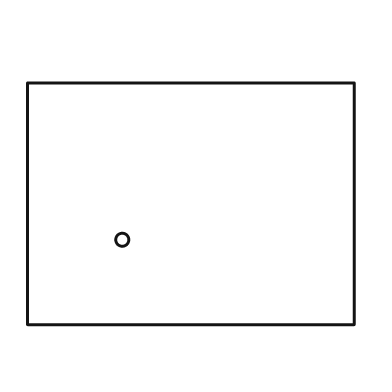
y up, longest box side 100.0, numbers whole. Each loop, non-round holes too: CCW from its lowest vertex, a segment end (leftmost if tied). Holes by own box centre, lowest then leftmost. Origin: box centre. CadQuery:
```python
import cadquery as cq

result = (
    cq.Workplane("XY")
    .moveTo(-50.0, -37.0)
    .lineTo(50.0, -37.0)
    .lineTo(50.0, 37.0)
    .lineTo(-50.0, 37.0)
    .close()
    .moveTo(-21.0, -11.0)
    .circle(2.0)
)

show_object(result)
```